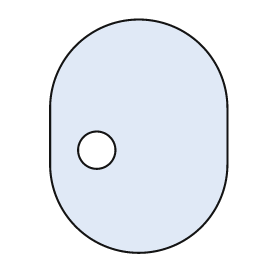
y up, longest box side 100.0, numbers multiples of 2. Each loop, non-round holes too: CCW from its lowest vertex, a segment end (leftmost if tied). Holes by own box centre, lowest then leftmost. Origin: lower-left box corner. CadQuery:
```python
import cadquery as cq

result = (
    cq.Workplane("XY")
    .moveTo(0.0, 38.0)
    .threePointArc((38.0, 0.0), (76.0, 38.0))
    .lineTo(76.0, 62.0)
    .threePointArc((38.0, 100.0), (0.0, 62.0))
    .close()
    .moveTo(20.0, 44.0)
    .circle(8.0)
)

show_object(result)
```